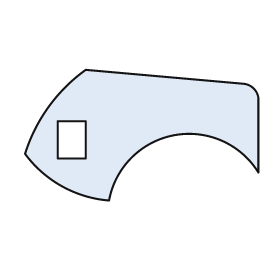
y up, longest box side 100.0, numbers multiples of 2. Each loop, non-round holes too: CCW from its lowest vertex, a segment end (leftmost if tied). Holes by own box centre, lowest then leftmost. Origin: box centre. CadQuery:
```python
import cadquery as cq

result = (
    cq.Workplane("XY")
    .moveTo(-14.0, -28.0)
    .threePointArc((14.0, 0.0), (50.0, -16.0))
    .lineTo(50.0, 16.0)
    .threePointArc((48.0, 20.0), (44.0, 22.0))
    .lineTo(-24.0, 28.0)
    .threePointArc((-40.0, 12.0), (-50.0, -8.0))
    .threePointArc((-34.0, -22.0), (-14.0, -28.0))
    .close()
    .moveTo(-36.0, -10.0)
    .lineTo(-24.0, -10.0)
    .lineTo(-24.0, 6.0)
    .lineTo(-36.0, 6.0)
    .close()
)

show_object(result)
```